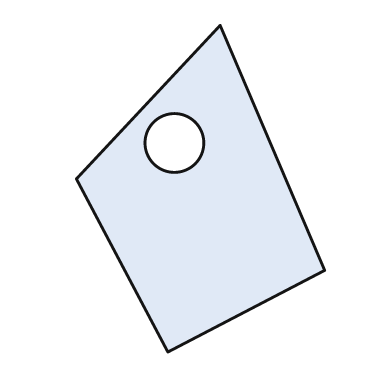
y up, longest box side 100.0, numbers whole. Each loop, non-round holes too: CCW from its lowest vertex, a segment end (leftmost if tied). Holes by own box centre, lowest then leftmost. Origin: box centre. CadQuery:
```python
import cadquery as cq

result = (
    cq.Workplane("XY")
    .moveTo(-10.0, -50.0)
    .lineTo(38.0, -25.0)
    .lineTo(6.0, 50.0)
    .lineTo(-38.0, 3.0)
    .close()
    .moveTo(-8.0, 14.0)
    .circle(9.0)
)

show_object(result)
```